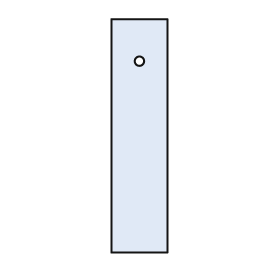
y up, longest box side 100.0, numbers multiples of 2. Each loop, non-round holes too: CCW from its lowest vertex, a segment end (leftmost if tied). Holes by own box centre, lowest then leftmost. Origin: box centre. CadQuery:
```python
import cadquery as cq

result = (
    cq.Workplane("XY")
    .moveTo(-12.0, -50.0)
    .lineTo(12.0, -50.0)
    .lineTo(12.0, 50.0)
    .lineTo(-12.0, 50.0)
    .close()
    .moveTo(0.0, 32.0)
    .circle(2.0)
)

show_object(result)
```